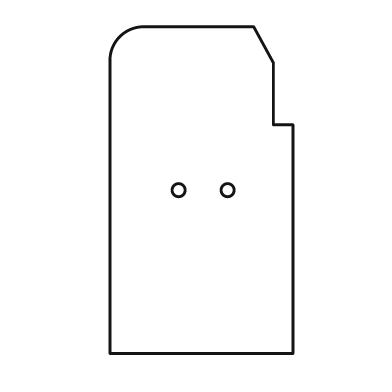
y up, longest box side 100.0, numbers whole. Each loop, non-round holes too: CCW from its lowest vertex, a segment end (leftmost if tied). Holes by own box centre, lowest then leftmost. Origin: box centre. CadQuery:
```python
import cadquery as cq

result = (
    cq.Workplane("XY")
    .moveTo(-28.0, -50.0)
    .lineTo(28.0, -50.0)
    .lineTo(28.0, 20.0)
    .lineTo(22.0, 20.0)
    .lineTo(22.0, 39.0)
    .lineTo(16.0, 50.0)
    .lineTo(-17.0, 50.0)
    .threePointArc((-25.0, 47.0), (-28.0, 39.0))
    .close()
    .moveTo(-7.0, 0.0)
    .circle(2.0)
    .moveTo(8.0, 0.0)
    .circle(2.0)
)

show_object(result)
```